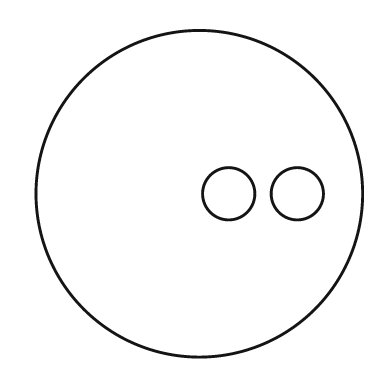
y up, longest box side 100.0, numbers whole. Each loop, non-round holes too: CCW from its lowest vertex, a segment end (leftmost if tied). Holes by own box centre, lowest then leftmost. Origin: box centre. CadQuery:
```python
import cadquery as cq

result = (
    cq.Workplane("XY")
    .moveTo(0.0, 0.0)
    .circle(50.0)
    .moveTo(9.0, 0.0)
    .circle(8.0)
    .moveTo(30.0, 0.0)
    .circle(8.0)
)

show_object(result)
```